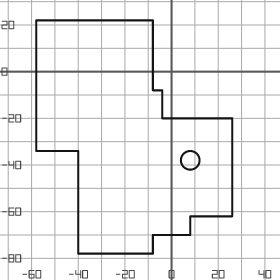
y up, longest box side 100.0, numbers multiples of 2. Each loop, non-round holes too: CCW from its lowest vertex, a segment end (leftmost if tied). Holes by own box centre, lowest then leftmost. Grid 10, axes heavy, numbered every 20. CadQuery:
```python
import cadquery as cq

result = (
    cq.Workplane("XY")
    .moveTo(-40.0, -78.0)
    .lineTo(-8.0, -78.0)
    .lineTo(-8.0, -70.0)
    .lineTo(8.0, -70.0)
    .lineTo(8.0, -62.0)
    .lineTo(26.0, -62.0)
    .lineTo(26.0, -20.0)
    .lineTo(-4.0, -20.0)
    .lineTo(-4.0, -8.0)
    .lineTo(-8.0, -8.0)
    .lineTo(-8.0, 22.0)
    .lineTo(-58.0, 22.0)
    .lineTo(-58.0, -34.0)
    .lineTo(-40.0, -34.0)
    .close()
    .moveTo(8.0, -38.0)
    .circle(4.0)
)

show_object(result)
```